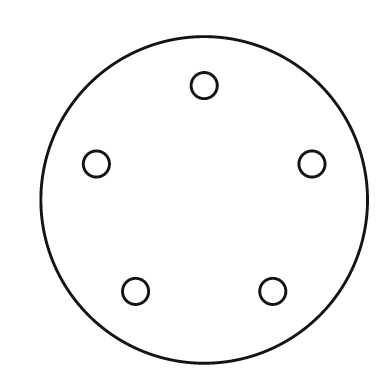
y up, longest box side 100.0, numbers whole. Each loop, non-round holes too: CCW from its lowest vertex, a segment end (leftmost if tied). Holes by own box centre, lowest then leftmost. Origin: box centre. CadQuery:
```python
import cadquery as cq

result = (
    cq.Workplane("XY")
    .moveTo(0.0, 0.0)
    .circle(50.0)
    .moveTo(-21.0, -28.0)
    .circle(4.0)
    .moveTo(21.0, -28.0)
    .circle(4.0)
    .moveTo(-33.0, 11.0)
    .circle(4.0)
    .moveTo(33.0, 11.0)
    .circle(4.0)
    .moveTo(0.0, 35.0)
    .circle(4.0)
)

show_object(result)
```